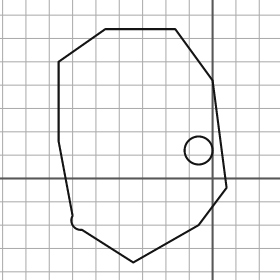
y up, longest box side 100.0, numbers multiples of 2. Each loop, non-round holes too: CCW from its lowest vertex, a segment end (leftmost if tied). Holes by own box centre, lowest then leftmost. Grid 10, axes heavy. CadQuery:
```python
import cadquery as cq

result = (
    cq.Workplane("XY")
    .moveTo(-34.0, -36.0)
    .lineTo(-6.0, -20.0)
    .lineTo(6.0, -4.0)
    .lineTo(0.0, 42.0)
    .lineTo(-16.0, 64.0)
    .lineTo(-46.0, 64.0)
    .lineTo(-66.0, 50.0)
    .lineTo(-66.0, 16.0)
    .lineTo(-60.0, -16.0)
    .threePointArc((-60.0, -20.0), (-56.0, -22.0))
    .close()
    .moveTo(-6.0, 12.0)
    .circle(6.0)
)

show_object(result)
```